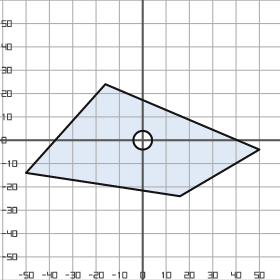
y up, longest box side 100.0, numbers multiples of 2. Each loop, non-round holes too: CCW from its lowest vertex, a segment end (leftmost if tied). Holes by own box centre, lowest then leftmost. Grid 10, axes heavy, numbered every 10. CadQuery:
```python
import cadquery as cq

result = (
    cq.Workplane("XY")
    .moveTo(16.0, -24.0)
    .lineTo(50.0, -4.0)
    .lineTo(-16.0, 24.0)
    .lineTo(-50.0, -14.0)
    .close()
    .moveTo(0.0, 0.0)
    .circle(4.0)
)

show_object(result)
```